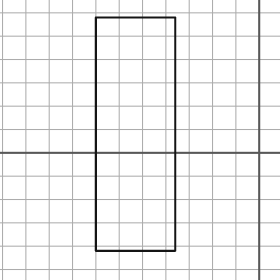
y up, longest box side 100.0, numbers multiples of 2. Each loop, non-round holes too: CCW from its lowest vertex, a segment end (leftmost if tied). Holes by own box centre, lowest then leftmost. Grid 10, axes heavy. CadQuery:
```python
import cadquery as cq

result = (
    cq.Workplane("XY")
    .moveTo(-70.0, -42.0)
    .lineTo(-36.0, -42.0)
    .lineTo(-36.0, 58.0)
    .lineTo(-70.0, 58.0)
    .close()
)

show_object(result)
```